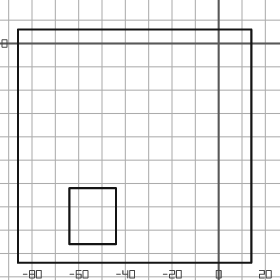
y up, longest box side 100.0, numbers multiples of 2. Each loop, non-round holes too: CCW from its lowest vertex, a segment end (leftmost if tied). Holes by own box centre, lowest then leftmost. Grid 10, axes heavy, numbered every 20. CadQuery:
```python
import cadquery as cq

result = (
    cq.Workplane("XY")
    .moveTo(-86.0, -94.0)
    .lineTo(14.0, -94.0)
    .lineTo(14.0, 6.0)
    .lineTo(-86.0, 6.0)
    .close()
    .moveTo(-64.0, -86.0)
    .lineTo(-44.0, -86.0)
    .lineTo(-44.0, -62.0)
    .lineTo(-64.0, -62.0)
    .close()
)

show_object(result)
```